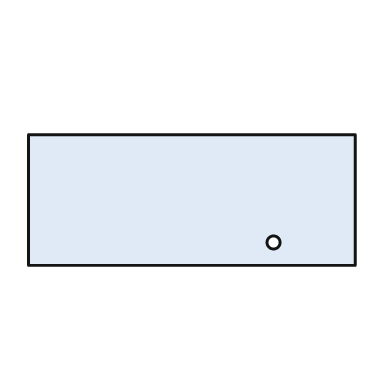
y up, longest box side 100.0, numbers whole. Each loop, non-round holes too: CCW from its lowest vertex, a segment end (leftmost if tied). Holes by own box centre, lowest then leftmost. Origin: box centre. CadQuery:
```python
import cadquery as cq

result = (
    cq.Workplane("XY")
    .moveTo(-50.0, -20.0)
    .lineTo(50.0, -20.0)
    .lineTo(50.0, 20.0)
    .lineTo(-50.0, 20.0)
    .close()
    .moveTo(25.0, -13.0)
    .circle(2.0)
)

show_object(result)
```